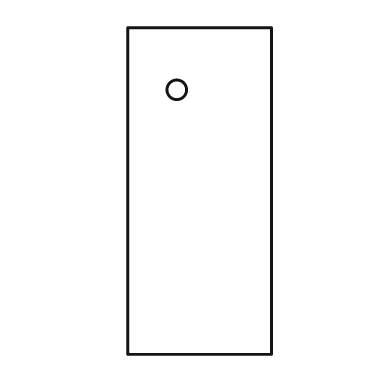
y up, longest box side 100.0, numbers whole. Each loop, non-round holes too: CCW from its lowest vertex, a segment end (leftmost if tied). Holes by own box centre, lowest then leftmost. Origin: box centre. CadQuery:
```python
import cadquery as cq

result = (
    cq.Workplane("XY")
    .moveTo(-22.0, -50.0)
    .lineTo(22.0, -50.0)
    .lineTo(22.0, 50.0)
    .lineTo(-22.0, 50.0)
    .close()
    .moveTo(-7.0, 31.0)
    .circle(3.0)
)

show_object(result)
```